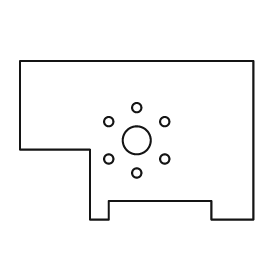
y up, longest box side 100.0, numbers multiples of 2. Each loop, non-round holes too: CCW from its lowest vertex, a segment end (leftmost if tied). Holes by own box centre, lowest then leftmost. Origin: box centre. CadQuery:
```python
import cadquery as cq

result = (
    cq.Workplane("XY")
    .moveTo(-20.0, -34.0)
    .lineTo(-12.0, -34.0)
    .lineTo(-12.0, -26.0)
    .lineTo(32.0, -26.0)
    .lineTo(32.0, -34.0)
    .lineTo(50.0, -34.0)
    .lineTo(50.0, 34.0)
    .lineTo(-50.0, 34.0)
    .lineTo(-50.0, -4.0)
    .lineTo(-20.0, -4.0)
    .close()
    .moveTo(0.0, -14.0)
    .circle(2.0)
    .moveTo(-12.0, -8.0)
    .circle(2.0)
    .moveTo(12.0, -8.0)
    .circle(2.0)
    .moveTo(0.0, 0.0)
    .circle(6.0)
    .moveTo(-12.0, 8.0)
    .circle(2.0)
    .moveTo(12.0, 8.0)
    .circle(2.0)
    .moveTo(0.0, 14.0)
    .circle(2.0)
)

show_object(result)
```